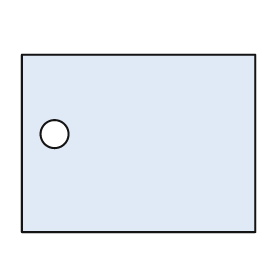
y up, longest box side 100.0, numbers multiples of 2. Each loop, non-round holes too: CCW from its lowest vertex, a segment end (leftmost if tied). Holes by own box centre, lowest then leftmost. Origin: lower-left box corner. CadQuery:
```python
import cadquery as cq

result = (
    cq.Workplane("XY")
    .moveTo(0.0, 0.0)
    .lineTo(100.0, 0.0)
    .lineTo(100.0, 76.0)
    .lineTo(0.0, 76.0)
    .close()
    .moveTo(14.0, 42.0)
    .circle(6.0)
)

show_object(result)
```